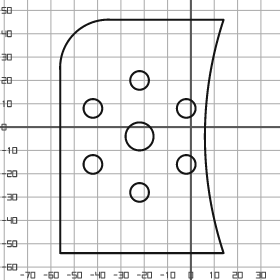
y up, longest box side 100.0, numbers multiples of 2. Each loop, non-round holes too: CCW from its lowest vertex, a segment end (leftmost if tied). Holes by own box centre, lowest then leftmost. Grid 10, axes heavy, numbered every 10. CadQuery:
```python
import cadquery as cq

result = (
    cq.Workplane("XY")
    .moveTo(-56.0, -54.0)
    .lineTo(14.0, -54.0)
    .threePointArc((6.0, -4.0), (14.0, 46.0))
    .lineTo(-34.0, 46.0)
    .threePointArc((-50.0, 40.0), (-56.0, 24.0))
    .close()
    .moveTo(-22.0, -28.0)
    .circle(4.0)
    .moveTo(-42.0, -16.0)
    .circle(4.0)
    .moveTo(-2.0, -16.0)
    .circle(4.0)
    .moveTo(-22.0, -4.0)
    .circle(6.0)
    .moveTo(-42.0, 8.0)
    .circle(4.0)
    .moveTo(-2.0, 8.0)
    .circle(4.0)
    .moveTo(-22.0, 20.0)
    .circle(4.0)
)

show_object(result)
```